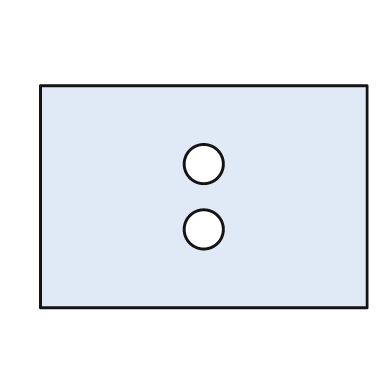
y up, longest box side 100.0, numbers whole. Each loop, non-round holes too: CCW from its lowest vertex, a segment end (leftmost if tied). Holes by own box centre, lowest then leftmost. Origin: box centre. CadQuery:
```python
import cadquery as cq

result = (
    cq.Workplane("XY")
    .moveTo(-50.0, -34.0)
    .lineTo(50.0, -34.0)
    .lineTo(50.0, 34.0)
    .lineTo(-50.0, 34.0)
    .close()
    .moveTo(0.0, -10.0)
    .circle(6.0)
    .moveTo(0.0, 10.0)
    .circle(6.0)
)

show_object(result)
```